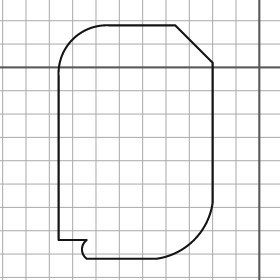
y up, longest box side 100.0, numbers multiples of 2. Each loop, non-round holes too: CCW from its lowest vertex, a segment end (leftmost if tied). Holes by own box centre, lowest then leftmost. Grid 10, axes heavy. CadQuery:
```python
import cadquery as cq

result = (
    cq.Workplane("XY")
    .moveTo(-74.0, -82.0)
    .lineTo(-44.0, -82.0)
    .threePointArc((-28.0, -74.0), (-20.0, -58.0))
    .lineTo(-20.0, 2.0)
    .lineTo(-36.0, 18.0)
    .lineTo(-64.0, 18.0)
    .threePointArc((-80.0, 12.0), (-86.0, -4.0))
    .lineTo(-86.0, -74.0)
    .lineTo(-74.0, -74.0)
    .threePointArc((-76.0, -78.0), (-74.0, -82.0))
    .close()
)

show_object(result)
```